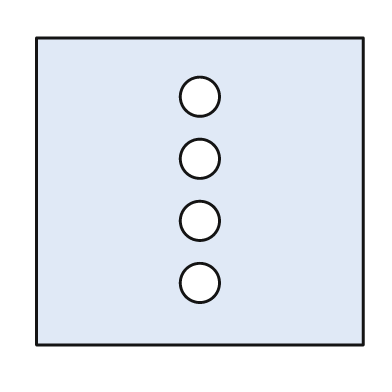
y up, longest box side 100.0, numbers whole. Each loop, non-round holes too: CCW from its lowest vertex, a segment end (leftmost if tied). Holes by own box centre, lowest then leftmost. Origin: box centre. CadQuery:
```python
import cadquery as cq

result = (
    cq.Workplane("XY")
    .moveTo(-50.0, -47.0)
    .lineTo(50.0, -47.0)
    .lineTo(50.0, 47.0)
    .lineTo(-50.0, 47.0)
    .close()
    .moveTo(0.0, -28.0)
    .circle(6.0)
    .moveTo(0.0, -9.0)
    .circle(6.0)
    .moveTo(0.0, 10.0)
    .circle(6.0)
    .moveTo(0.0, 29.0)
    .circle(6.0)
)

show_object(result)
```